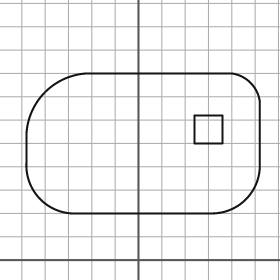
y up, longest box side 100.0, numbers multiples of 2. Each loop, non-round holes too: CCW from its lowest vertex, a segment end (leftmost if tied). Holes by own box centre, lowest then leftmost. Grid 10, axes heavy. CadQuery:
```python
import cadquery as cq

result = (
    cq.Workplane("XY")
    .moveTo(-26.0, 20.0)
    .lineTo(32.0, 20.0)
    .threePointArc((46.0, 26.0), (52.0, 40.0))
    .lineTo(52.0, 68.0)
    .threePointArc((48.0, 76.0), (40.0, 80.0))
    .lineTo(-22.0, 80.0)
    .threePointArc((-40.0, 72.0), (-48.0, 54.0))
    .lineTo(-48.0, 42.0)
    .threePointArc((-42.0, 26.0), (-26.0, 20.0))
    .close()
    .moveTo(24.0, 50.0)
    .lineTo(36.0, 50.0)
    .lineTo(36.0, 62.0)
    .lineTo(24.0, 62.0)
    .close()
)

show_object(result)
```